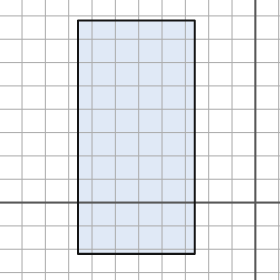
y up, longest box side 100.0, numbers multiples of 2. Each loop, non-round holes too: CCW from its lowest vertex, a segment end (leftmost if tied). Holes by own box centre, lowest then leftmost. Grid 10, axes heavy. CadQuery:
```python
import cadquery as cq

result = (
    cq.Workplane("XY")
    .moveTo(-76.0, -22.0)
    .lineTo(-26.0, -22.0)
    .lineTo(-26.0, 78.0)
    .lineTo(-76.0, 78.0)
    .close()
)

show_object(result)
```